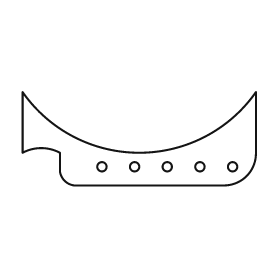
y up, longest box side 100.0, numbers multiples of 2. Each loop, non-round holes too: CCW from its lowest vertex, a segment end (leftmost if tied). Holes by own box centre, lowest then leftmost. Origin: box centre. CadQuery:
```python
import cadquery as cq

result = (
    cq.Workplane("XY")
    .moveTo(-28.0, -20.0)
    .lineTo(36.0, -20.0)
    .threePointArc((46.0, -16.0), (50.0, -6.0))
    .lineTo(50.0, 20.0)
    .threePointArc((0.0, -6.0), (-50.0, 20.0))
    .lineTo(-50.0, -6.0)
    .threePointArc((-42.0, -4.0), (-34.0, -6.0))
    .lineTo(-34.0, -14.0)
    .threePointArc((-32.0, -18.0), (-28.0, -20.0))
    .close()
    .moveTo(-16.0, -12.0)
    .circle(2.0)
    .moveTo(-2.0, -12.0)
    .circle(2.0)
    .moveTo(12.0, -12.0)
    .circle(2.0)
    .moveTo(26.0, -12.0)
    .circle(2.0)
    .moveTo(40.0, -12.0)
    .circle(2.0)
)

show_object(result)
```